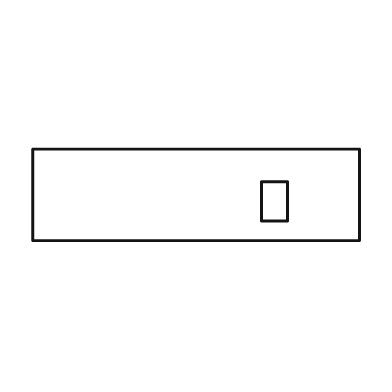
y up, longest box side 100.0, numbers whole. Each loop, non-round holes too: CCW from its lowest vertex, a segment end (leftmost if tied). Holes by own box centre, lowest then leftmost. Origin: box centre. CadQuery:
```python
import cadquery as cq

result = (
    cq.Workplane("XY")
    .moveTo(-50.0, -14.0)
    .lineTo(50.0, -14.0)
    .lineTo(50.0, 14.0)
    .lineTo(-50.0, 14.0)
    .close()
    .moveTo(20.0, -8.0)
    .lineTo(28.0, -8.0)
    .lineTo(28.0, 4.0)
    .lineTo(20.0, 4.0)
    .close()
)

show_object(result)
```